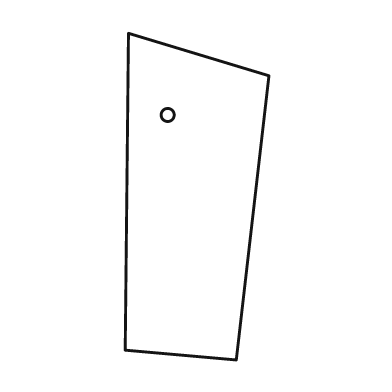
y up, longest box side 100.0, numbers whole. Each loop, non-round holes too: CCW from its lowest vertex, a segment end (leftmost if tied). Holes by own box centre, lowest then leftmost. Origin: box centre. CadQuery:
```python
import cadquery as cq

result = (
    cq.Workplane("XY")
    .moveTo(12.0, -50.0)
    .lineTo(22.0, 37.0)
    .lineTo(-21.0, 50.0)
    .lineTo(-22.0, -47.0)
    .close()
    .moveTo(-9.0, 25.0)
    .circle(2.0)
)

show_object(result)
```